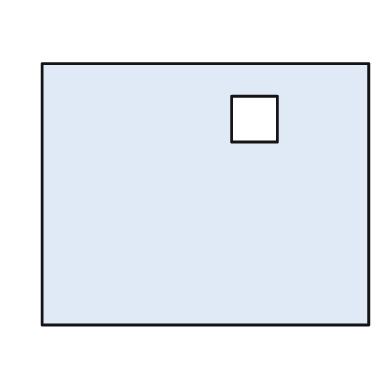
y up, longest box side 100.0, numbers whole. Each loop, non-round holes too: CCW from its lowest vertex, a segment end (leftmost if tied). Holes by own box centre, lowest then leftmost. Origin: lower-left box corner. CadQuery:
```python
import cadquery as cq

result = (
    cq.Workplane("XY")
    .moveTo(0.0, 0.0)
    .lineTo(100.0, 0.0)
    .lineTo(100.0, 80.0)
    .lineTo(0.0, 80.0)
    .close()
    .moveTo(58.0, 56.0)
    .lineTo(72.0, 56.0)
    .lineTo(72.0, 70.0)
    .lineTo(58.0, 70.0)
    .close()
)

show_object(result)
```